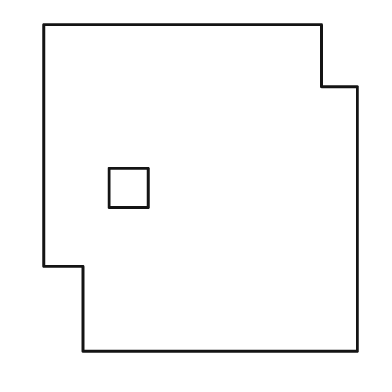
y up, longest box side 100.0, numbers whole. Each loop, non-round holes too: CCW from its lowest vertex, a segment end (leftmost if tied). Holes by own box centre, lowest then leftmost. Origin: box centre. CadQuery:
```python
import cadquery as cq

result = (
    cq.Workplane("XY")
    .moveTo(-36.0, -50.0)
    .lineTo(48.0, -50.0)
    .lineTo(48.0, 31.0)
    .lineTo(37.0, 31.0)
    .lineTo(37.0, 50.0)
    .lineTo(-48.0, 50.0)
    .lineTo(-48.0, -24.0)
    .lineTo(-36.0, -24.0)
    .close()
    .moveTo(-28.0, -6.0)
    .lineTo(-16.0, -6.0)
    .lineTo(-16.0, 6.0)
    .lineTo(-28.0, 6.0)
    .close()
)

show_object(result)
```